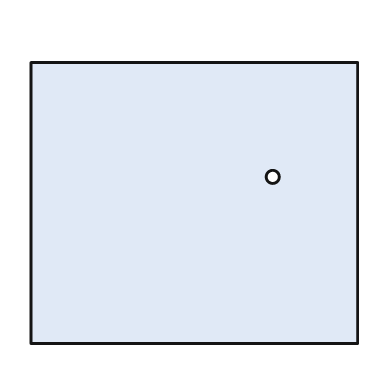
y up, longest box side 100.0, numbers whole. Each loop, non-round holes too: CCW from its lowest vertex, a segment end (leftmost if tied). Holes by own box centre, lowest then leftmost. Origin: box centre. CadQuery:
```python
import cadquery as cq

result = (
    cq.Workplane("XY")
    .moveTo(-50.0, -43.0)
    .lineTo(50.0, -43.0)
    .lineTo(50.0, 43.0)
    .lineTo(-50.0, 43.0)
    .close()
    .moveTo(24.0, 8.0)
    .circle(2.0)
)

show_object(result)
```